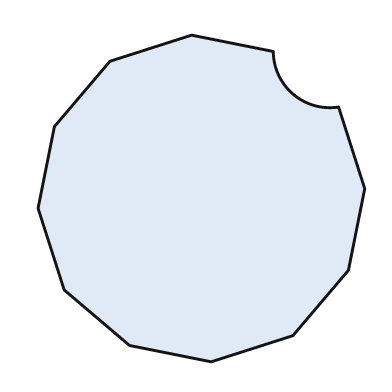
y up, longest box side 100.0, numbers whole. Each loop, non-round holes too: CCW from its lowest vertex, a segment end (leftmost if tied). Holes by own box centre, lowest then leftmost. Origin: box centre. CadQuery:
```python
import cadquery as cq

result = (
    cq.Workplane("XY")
    .moveTo(3.0, -50.0)
    .lineTo(28.0, -42.0)
    .lineTo(45.0, -22.0)
    .lineTo(50.0, 3.0)
    .lineTo(42.0, 28.0)
    .threePointArc((28.0, 32.0), (22.0, 45.0))
    .lineTo(-3.0, 50.0)
    .lineTo(-28.0, 42.0)
    .lineTo(-45.0, 22.0)
    .lineTo(-50.0, -3.0)
    .lineTo(-42.0, -28.0)
    .lineTo(-22.0, -45.0)
    .close()
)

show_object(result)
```